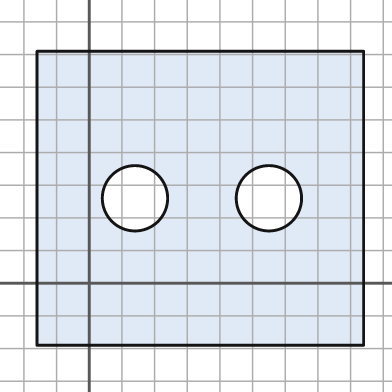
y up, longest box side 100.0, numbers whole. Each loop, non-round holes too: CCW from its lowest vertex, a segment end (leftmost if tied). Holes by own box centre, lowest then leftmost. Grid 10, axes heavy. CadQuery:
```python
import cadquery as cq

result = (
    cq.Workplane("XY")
    .moveTo(-16.0, -19.0)
    .lineTo(84.0, -19.0)
    .lineTo(84.0, 71.0)
    .lineTo(-16.0, 71.0)
    .close()
    .moveTo(14.0, 26.0)
    .circle(10.0)
    .moveTo(55.0, 26.0)
    .circle(10.0)
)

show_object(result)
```